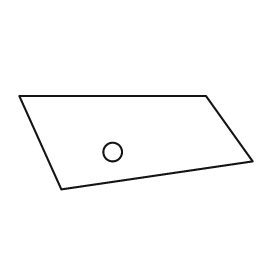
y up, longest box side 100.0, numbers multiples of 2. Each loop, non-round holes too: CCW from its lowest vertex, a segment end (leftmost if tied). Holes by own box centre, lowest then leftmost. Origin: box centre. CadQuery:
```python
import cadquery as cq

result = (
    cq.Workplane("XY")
    .moveTo(-32.0, -20.0)
    .lineTo(50.0, -8.0)
    .lineTo(30.0, 20.0)
    .lineTo(-50.0, 20.0)
    .close()
    .moveTo(-10.0, -4.0)
    .circle(4.0)
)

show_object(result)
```